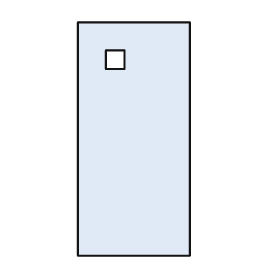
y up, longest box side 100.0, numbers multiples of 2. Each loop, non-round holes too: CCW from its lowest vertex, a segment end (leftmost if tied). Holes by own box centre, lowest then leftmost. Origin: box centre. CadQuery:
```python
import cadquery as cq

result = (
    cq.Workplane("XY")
    .moveTo(-24.0, -50.0)
    .lineTo(24.0, -50.0)
    .lineTo(24.0, 50.0)
    .lineTo(-24.0, 50.0)
    .close()
    .moveTo(-12.0, 30.0)
    .lineTo(-4.0, 30.0)
    .lineTo(-4.0, 38.0)
    .lineTo(-12.0, 38.0)
    .close()
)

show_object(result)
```